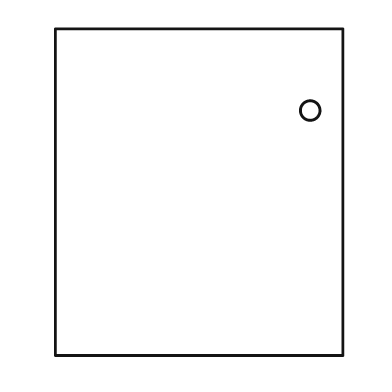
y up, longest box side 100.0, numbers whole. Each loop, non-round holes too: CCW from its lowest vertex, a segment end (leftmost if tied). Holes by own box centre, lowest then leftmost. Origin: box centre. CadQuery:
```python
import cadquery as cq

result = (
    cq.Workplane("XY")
    .moveTo(-44.0, -50.0)
    .lineTo(44.0, -50.0)
    .lineTo(44.0, 50.0)
    .lineTo(-44.0, 50.0)
    .close()
    .moveTo(34.0, 25.0)
    .circle(3.0)
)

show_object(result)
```